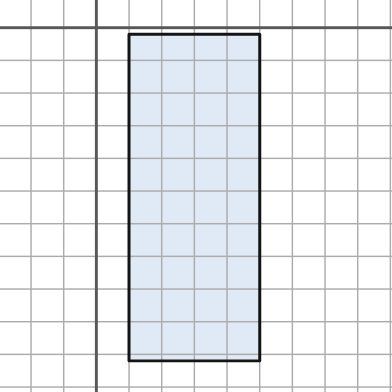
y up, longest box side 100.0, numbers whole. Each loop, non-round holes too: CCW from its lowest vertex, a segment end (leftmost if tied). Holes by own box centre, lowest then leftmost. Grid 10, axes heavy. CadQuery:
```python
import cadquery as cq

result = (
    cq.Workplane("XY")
    .moveTo(10.0, -102.0)
    .lineTo(50.0, -102.0)
    .lineTo(50.0, -2.0)
    .lineTo(10.0, -2.0)
    .close()
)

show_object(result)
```